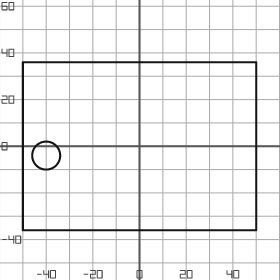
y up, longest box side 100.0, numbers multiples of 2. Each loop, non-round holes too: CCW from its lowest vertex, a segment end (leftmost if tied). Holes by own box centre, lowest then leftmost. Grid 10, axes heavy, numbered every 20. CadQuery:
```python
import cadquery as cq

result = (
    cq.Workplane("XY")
    .moveTo(-50.0, -36.0)
    .lineTo(50.0, -36.0)
    .lineTo(50.0, 36.0)
    .lineTo(-50.0, 36.0)
    .close()
    .moveTo(-40.0, -4.0)
    .circle(6.0)
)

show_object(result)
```